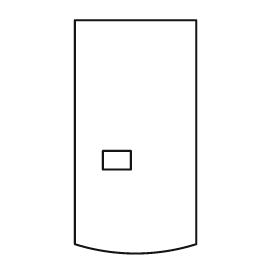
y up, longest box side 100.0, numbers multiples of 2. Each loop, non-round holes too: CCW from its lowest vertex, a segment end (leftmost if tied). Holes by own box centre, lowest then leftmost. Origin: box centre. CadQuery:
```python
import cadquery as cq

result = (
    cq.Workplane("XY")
    .moveTo(-26.0, -46.0)
    .threePointArc((0.0, -50.0), (26.0, -46.0))
    .lineTo(26.0, 50.0)
    .lineTo(-26.0, 50.0)
    .close()
    .moveTo(-14.0, -14.0)
    .lineTo(-2.0, -14.0)
    .lineTo(-2.0, -6.0)
    .lineTo(-14.0, -6.0)
    .close()
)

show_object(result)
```